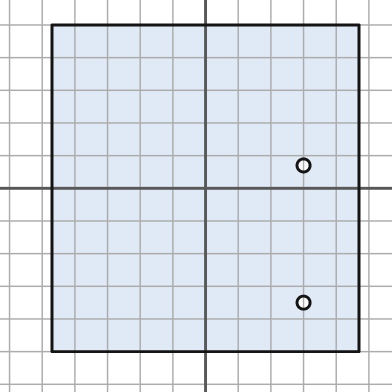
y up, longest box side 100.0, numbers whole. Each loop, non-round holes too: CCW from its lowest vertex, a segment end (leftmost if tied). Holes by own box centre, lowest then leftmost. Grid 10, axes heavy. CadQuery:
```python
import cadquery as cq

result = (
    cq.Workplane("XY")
    .moveTo(-47.0, -50.0)
    .lineTo(47.0, -50.0)
    .lineTo(47.0, 50.0)
    .lineTo(-47.0, 50.0)
    .close()
    .moveTo(30.0, -35.0)
    .circle(2.0)
    .moveTo(30.0, 7.0)
    .circle(2.0)
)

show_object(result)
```